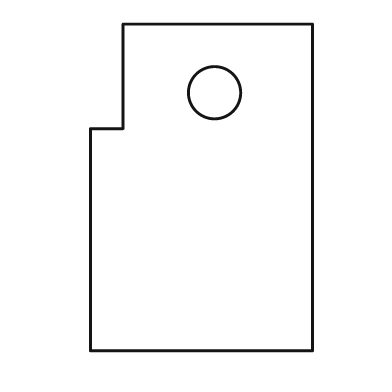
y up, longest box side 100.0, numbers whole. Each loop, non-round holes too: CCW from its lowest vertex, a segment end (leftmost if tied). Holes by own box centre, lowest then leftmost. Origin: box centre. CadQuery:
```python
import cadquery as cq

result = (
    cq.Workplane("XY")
    .moveTo(-34.0, -50.0)
    .lineTo(34.0, -50.0)
    .lineTo(34.0, 50.0)
    .lineTo(-24.0, 50.0)
    .lineTo(-24.0, 18.0)
    .lineTo(-34.0, 18.0)
    .close()
    .moveTo(4.0, 29.0)
    .circle(8.0)
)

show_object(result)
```